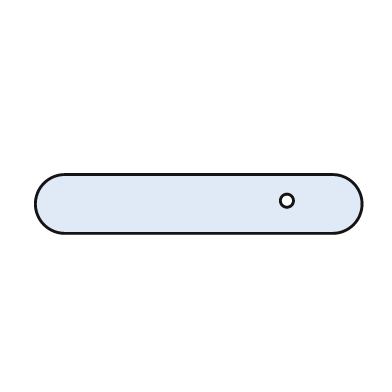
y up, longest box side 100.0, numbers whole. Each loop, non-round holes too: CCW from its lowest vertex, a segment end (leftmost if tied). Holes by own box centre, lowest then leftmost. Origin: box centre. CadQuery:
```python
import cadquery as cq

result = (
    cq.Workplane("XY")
    .moveTo(-41.0, -9.0)
    .lineTo(41.0, -9.0)
    .threePointArc((50.0, 0.0), (41.0, 9.0))
    .lineTo(-41.0, 9.0)
    .threePointArc((-50.0, 0.0), (-41.0, -9.0))
    .close()
    .moveTo(27.0, 1.0)
    .circle(2.0)
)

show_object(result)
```